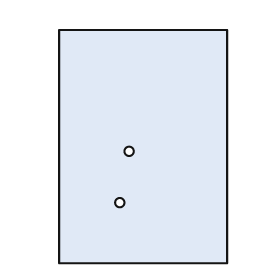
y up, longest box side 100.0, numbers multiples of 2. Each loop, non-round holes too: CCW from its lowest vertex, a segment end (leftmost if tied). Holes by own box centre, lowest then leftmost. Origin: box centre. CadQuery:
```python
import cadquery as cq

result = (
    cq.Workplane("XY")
    .moveTo(-36.0, -50.0)
    .lineTo(36.0, -50.0)
    .lineTo(36.0, 50.0)
    .lineTo(-36.0, 50.0)
    .close()
    .moveTo(-10.0, -24.0)
    .circle(2.0)
    .moveTo(-6.0, -2.0)
    .circle(2.0)
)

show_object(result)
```